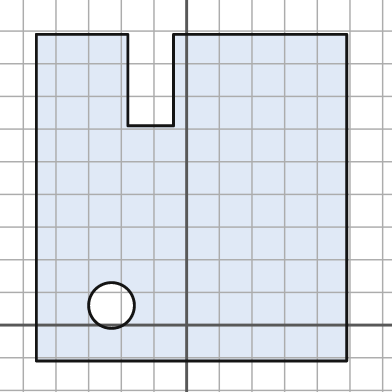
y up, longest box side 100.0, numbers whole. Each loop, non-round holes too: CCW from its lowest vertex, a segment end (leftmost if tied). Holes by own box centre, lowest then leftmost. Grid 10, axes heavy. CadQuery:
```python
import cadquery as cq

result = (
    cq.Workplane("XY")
    .moveTo(-46.0, -11.0)
    .lineTo(49.0, -11.0)
    .lineTo(49.0, 89.0)
    .lineTo(-4.0, 89.0)
    .lineTo(-4.0, 61.0)
    .lineTo(-18.0, 61.0)
    .lineTo(-18.0, 89.0)
    .lineTo(-46.0, 89.0)
    .close()
    .moveTo(-23.0, 6.0)
    .circle(7.0)
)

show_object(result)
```